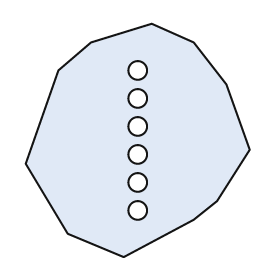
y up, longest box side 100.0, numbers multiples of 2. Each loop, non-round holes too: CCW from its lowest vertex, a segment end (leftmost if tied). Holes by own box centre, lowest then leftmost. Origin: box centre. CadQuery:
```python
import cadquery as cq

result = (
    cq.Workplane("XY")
    .moveTo(-6.0, -50.0)
    .lineTo(24.0, -34.0)
    .lineTo(34.0, -26.0)
    .lineTo(48.0, -4.0)
    .lineTo(38.0, 24.0)
    .lineTo(24.0, 42.0)
    .lineTo(6.0, 50.0)
    .lineTo(-20.0, 42.0)
    .lineTo(-34.0, 30.0)
    .lineTo(-48.0, -10.0)
    .lineTo(-30.0, -40.0)
    .close()
    .moveTo(0.0, -30.0)
    .circle(4.0)
    .moveTo(0.0, -18.0)
    .circle(4.0)
    .moveTo(0.0, -6.0)
    .circle(4.0)
    .moveTo(0.0, 6.0)
    .circle(4.0)
    .moveTo(0.0, 18.0)
    .circle(4.0)
    .moveTo(0.0, 30.0)
    .circle(4.0)
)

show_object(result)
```